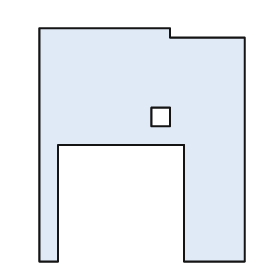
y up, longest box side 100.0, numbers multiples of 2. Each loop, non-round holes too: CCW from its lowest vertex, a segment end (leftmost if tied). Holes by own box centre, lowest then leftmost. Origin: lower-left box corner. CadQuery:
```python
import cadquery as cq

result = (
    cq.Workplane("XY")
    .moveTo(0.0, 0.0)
    .lineTo(8.0, 0.0)
    .lineTo(8.0, 50.0)
    .lineTo(62.0, 50.0)
    .lineTo(62.0, 0.0)
    .lineTo(88.0, 0.0)
    .lineTo(88.0, 96.0)
    .lineTo(56.0, 96.0)
    .lineTo(56.0, 100.0)
    .lineTo(0.0, 100.0)
    .close()
    .moveTo(48.0, 58.0)
    .lineTo(56.0, 58.0)
    .lineTo(56.0, 66.0)
    .lineTo(48.0, 66.0)
    .close()
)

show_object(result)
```